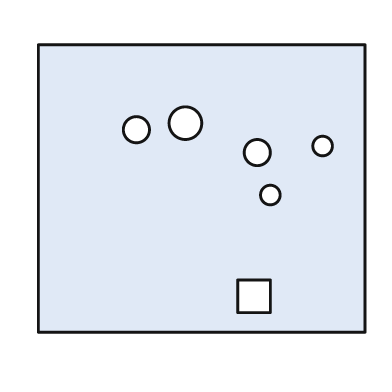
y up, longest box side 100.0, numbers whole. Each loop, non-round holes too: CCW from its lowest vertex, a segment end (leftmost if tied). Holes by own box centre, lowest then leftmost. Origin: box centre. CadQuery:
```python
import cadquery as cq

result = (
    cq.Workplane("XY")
    .moveTo(-50.0, -44.0)
    .lineTo(50.0, -44.0)
    .lineTo(50.0, 44.0)
    .lineTo(-50.0, 44.0)
    .close()
    .moveTo(11.0, -38.0)
    .lineTo(21.0, -38.0)
    .lineTo(21.0, -28.0)
    .lineTo(11.0, -28.0)
    .close()
    .moveTo(21.0, -2.0)
    .circle(3.0)
    .moveTo(17.0, 11.0)
    .circle(4.0)
    .moveTo(37.0, 13.0)
    .circle(3.0)
    .moveTo(-20.0, 18.0)
    .circle(4.0)
    .moveTo(-5.0, 20.0)
    .circle(5.0)
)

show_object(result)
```